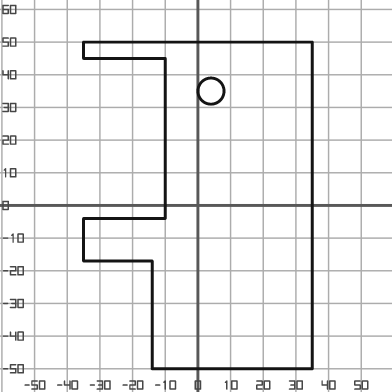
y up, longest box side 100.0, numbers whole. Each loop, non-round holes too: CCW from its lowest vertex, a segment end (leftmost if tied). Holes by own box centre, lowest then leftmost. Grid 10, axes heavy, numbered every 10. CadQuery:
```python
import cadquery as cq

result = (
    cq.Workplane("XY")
    .moveTo(-14.0, -50.0)
    .lineTo(35.0, -50.0)
    .lineTo(35.0, 50.0)
    .lineTo(-35.0, 50.0)
    .lineTo(-35.0, 45.0)
    .lineTo(-10.0, 45.0)
    .lineTo(-10.0, -4.0)
    .lineTo(-35.0, -4.0)
    .lineTo(-35.0, -17.0)
    .lineTo(-14.0, -17.0)
    .close()
    .moveTo(4.0, 35.0)
    .circle(4.0)
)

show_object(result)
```